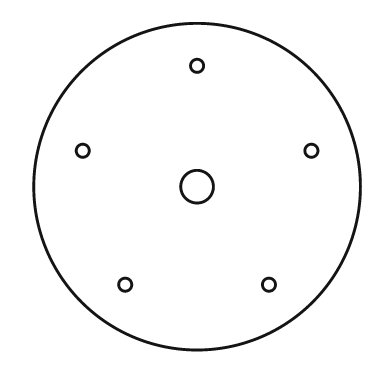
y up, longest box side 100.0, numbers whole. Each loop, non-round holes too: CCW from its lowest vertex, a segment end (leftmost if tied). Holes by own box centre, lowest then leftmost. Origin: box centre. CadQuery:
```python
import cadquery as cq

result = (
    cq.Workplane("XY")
    .moveTo(0.0, 0.0)
    .circle(50.0)
    .moveTo(-22.0, -30.0)
    .circle(2.0)
    .moveTo(22.0, -30.0)
    .circle(2.0)
    .moveTo(0.0, 0.0)
    .circle(5.0)
    .moveTo(-35.0, 11.0)
    .circle(2.0)
    .moveTo(35.0, 11.0)
    .circle(2.0)
    .moveTo(0.0, 37.0)
    .circle(2.0)
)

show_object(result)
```